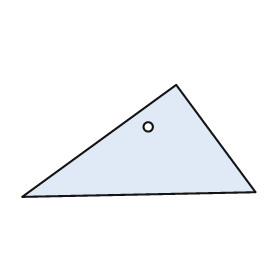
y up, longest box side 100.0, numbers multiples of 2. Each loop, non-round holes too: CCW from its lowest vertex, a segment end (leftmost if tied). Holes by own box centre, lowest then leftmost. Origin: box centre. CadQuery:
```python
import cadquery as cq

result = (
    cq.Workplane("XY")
    .moveTo(-50.0, -24.0)
    .lineTo(50.0, -22.0)
    .lineTo(16.0, 24.0)
    .close()
    .moveTo(4.0, 6.0)
    .circle(2.0)
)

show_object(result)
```